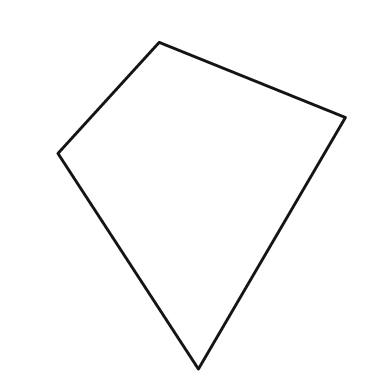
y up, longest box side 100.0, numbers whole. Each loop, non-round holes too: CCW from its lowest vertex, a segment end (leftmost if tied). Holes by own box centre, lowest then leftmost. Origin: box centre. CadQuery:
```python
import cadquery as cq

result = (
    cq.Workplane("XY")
    .moveTo(-1.0, -50.0)
    .lineTo(44.0, 27.0)
    .lineTo(-13.0, 50.0)
    .lineTo(-44.0, 16.0)
    .close()
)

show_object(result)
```